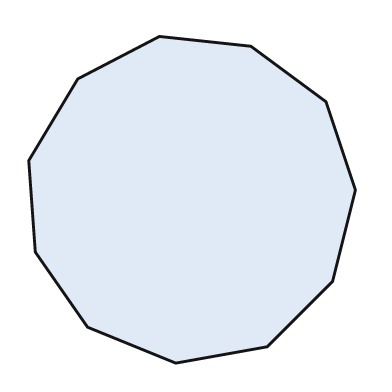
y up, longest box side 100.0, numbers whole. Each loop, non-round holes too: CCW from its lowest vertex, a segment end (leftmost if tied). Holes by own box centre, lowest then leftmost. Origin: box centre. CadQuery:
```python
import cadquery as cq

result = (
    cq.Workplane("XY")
    .moveTo(-5.0, -50.0)
    .lineTo(23.0, -45.0)
    .lineTo(43.0, -25.0)
    .lineTo(50.0, 3.0)
    .lineTo(41.0, 30.0)
    .lineTo(18.0, 47.0)
    .lineTo(-10.0, 50.0)
    .lineTo(-35.0, 37.0)
    .lineTo(-50.0, 12.0)
    .lineTo(-48.0, -16.0)
    .lineTo(-32.0, -39.0)
    .close()
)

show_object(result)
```